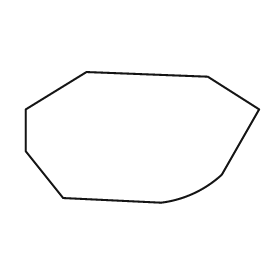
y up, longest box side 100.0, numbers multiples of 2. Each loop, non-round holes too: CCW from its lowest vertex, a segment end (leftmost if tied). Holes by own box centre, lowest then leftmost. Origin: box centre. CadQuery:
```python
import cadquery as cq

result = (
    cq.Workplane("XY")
    .moveTo(8.0, -28.0)
    .threePointArc((22.0, -24.0), (34.0, -16.0))
    .lineTo(50.0, 12.0)
    .lineTo(28.0, 26.0)
    .lineTo(-24.0, 28.0)
    .lineTo(-50.0, 12.0)
    .lineTo(-50.0, -6.0)
    .lineTo(-34.0, -26.0)
    .close()
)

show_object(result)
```